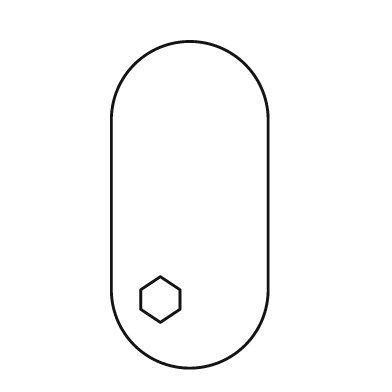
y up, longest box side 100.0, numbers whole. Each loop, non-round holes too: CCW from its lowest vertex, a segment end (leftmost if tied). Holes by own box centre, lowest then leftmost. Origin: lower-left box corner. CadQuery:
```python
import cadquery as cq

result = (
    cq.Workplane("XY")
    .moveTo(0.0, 24.0)
    .threePointArc((24.0, 0.0), (48.0, 24.0))
    .lineTo(48.0, 76.0)
    .threePointArc((24.0, 100.0), (0.0, 76.0))
    .close()
    .moveTo(15.0, 14.0)
    .lineTo(21.0, 18.0)
    .lineTo(21.0, 24.0)
    .lineTo(15.0, 28.0)
    .lineTo(9.0, 24.0)
    .lineTo(9.0, 18.0)
    .close()
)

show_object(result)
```